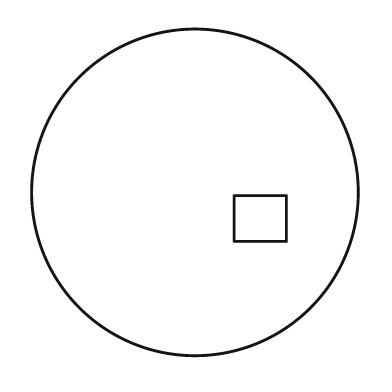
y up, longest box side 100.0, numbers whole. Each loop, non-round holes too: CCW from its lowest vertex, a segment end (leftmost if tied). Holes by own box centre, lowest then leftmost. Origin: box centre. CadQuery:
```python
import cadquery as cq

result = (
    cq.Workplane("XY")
    .moveTo(0.0, 0.0)
    .circle(50.0)
    .moveTo(12.0, -15.0)
    .lineTo(28.0, -15.0)
    .lineTo(28.0, -1.0)
    .lineTo(12.0, -1.0)
    .close()
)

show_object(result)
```